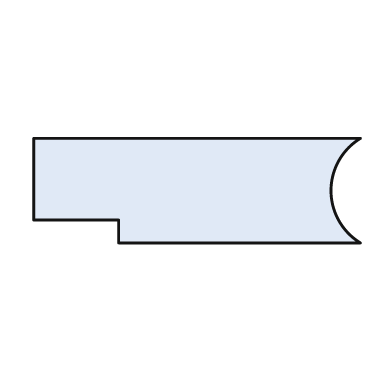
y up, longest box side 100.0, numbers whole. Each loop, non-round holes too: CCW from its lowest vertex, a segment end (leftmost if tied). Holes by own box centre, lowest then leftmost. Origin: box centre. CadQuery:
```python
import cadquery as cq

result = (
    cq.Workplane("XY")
    .moveTo(-24.0, -16.0)
    .lineTo(50.0, -16.0)
    .threePointArc((41.0, 0.0), (50.0, 16.0))
    .lineTo(-50.0, 16.0)
    .lineTo(-50.0, -9.0)
    .lineTo(-24.0, -9.0)
    .close()
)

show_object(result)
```